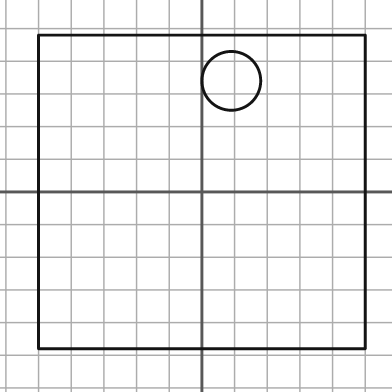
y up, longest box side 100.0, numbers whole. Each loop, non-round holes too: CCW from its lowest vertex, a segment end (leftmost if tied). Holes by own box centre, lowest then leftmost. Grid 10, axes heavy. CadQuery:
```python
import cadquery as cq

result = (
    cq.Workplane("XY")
    .moveTo(-50.0, -48.0)
    .lineTo(50.0, -48.0)
    .lineTo(50.0, 48.0)
    .lineTo(-50.0, 48.0)
    .close()
    .moveTo(9.0, 34.0)
    .circle(9.0)
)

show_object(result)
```